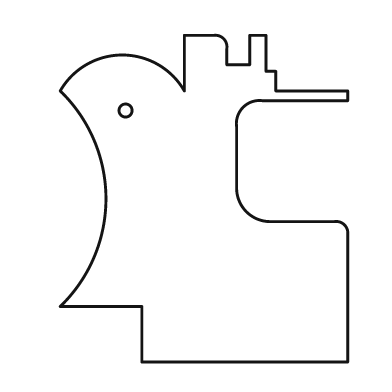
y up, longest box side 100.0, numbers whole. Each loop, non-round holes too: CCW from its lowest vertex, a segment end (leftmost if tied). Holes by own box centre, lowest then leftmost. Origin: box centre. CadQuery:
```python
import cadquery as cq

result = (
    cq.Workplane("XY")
    .moveTo(-19.0, -50.0)
    .lineTo(44.0, -50.0)
    .lineTo(44.0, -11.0)
    .threePointArc((43.0, -8.0), (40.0, -7.0))
    .lineTo(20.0, -7.0)
    .threePointArc((13.0, -4.0), (10.0, 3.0))
    .lineTo(10.0, 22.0)
    .threePointArc((12.0, 28.0), (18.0, 30.0))
    .lineTo(44.0, 30.0)
    .lineTo(44.0, 33.0)
    .lineTo(22.0, 33.0)
    .lineTo(22.0, 39.0)
    .lineTo(19.0, 39.0)
    .lineTo(19.0, 50.0)
    .lineTo(14.0, 50.0)
    .lineTo(14.0, 41.0)
    .lineTo(7.0, 41.0)
    .lineTo(7.0, 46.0)
    .threePointArc((6.0, 49.0), (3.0, 50.0))
    .lineTo(-6.0, 50.0)
    .lineTo(-6.0, 33.0)
    .threePointArc((-25.0, 44.0), (-44.0, 33.0))
    .threePointArc((-30.0, 0.0), (-44.0, -33.0))
    .lineTo(-19.0, -33.0)
    .close()
    .moveTo(-24.0, 27.0)
    .circle(2.0)
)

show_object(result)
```